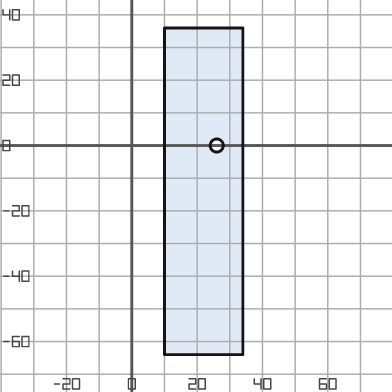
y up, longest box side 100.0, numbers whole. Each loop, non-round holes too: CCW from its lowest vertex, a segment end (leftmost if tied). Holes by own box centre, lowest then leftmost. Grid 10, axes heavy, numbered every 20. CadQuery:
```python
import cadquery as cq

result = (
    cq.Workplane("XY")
    .moveTo(10.0, -64.0)
    .lineTo(34.0, -64.0)
    .lineTo(34.0, 36.0)
    .lineTo(10.0, 36.0)
    .close()
    .moveTo(26.0, 0.0)
    .circle(2.0)
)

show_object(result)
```